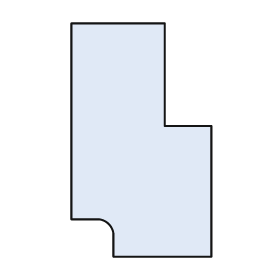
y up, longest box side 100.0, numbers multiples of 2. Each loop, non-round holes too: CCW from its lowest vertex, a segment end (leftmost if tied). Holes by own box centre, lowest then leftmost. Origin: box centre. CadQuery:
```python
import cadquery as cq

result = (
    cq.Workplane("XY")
    .moveTo(-12.0, -50.0)
    .lineTo(30.0, -50.0)
    .lineTo(30.0, 6.0)
    .lineTo(10.0, 6.0)
    .lineTo(10.0, 50.0)
    .lineTo(-30.0, 50.0)
    .lineTo(-30.0, -34.0)
    .lineTo(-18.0, -34.0)
    .threePointArc((-14.0, -36.0), (-12.0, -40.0))
    .close()
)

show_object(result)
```